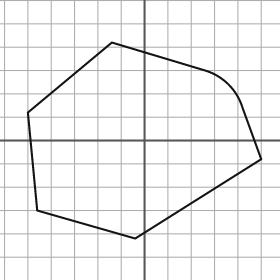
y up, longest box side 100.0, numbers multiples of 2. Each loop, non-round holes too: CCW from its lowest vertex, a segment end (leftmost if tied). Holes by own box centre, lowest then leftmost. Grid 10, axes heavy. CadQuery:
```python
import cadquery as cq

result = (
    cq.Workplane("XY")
    .moveTo(-4.0, -42.0)
    .lineTo(50.0, -8.0)
    .lineTo(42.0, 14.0)
    .threePointArc((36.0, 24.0), (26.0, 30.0))
    .lineTo(-14.0, 42.0)
    .lineTo(-50.0, 12.0)
    .lineTo(-46.0, -30.0)
    .close()
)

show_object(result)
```